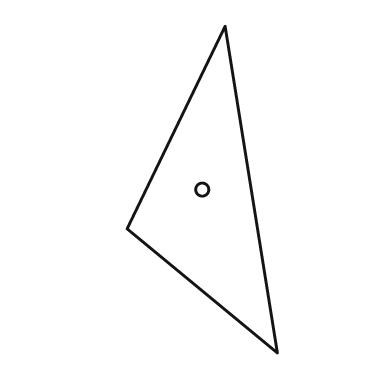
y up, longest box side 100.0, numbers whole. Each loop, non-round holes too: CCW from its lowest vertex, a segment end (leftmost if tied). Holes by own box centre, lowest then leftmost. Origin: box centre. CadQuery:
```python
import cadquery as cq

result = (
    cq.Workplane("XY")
    .moveTo(23.0, -50.0)
    .lineTo(7.0, 50.0)
    .lineTo(-23.0, -12.0)
    .close()
    .moveTo(0.0, 0.0)
    .circle(2.0)
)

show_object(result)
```